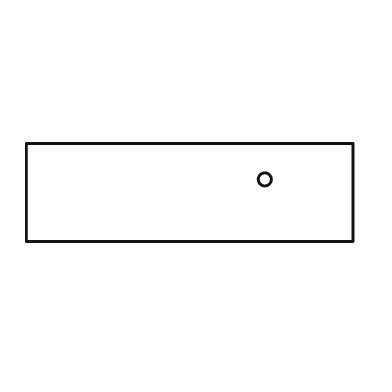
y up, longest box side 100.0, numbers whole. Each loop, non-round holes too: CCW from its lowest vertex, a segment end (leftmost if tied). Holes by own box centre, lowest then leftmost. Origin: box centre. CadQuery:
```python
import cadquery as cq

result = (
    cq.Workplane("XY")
    .moveTo(-50.0, -15.0)
    .lineTo(50.0, -15.0)
    .lineTo(50.0, 15.0)
    .lineTo(-50.0, 15.0)
    .close()
    .moveTo(23.0, 4.0)
    .circle(2.0)
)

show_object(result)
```